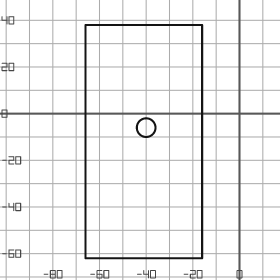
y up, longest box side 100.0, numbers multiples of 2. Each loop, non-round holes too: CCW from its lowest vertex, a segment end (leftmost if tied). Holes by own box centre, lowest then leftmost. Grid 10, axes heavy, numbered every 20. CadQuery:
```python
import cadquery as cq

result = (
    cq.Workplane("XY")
    .moveTo(-66.0, -62.0)
    .lineTo(-16.0, -62.0)
    .lineTo(-16.0, 38.0)
    .lineTo(-66.0, 38.0)
    .close()
    .moveTo(-40.0, -6.0)
    .circle(4.0)
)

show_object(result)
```